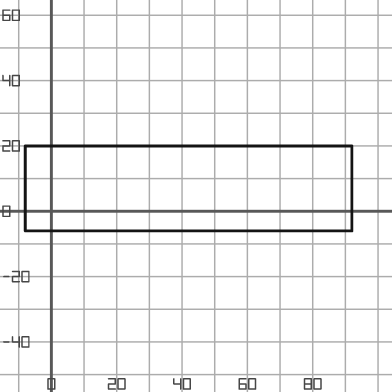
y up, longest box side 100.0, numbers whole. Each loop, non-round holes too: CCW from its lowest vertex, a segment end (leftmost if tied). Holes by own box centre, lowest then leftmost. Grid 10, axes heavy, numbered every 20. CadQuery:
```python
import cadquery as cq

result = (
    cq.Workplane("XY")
    .moveTo(-8.0, -6.0)
    .lineTo(92.0, -6.0)
    .lineTo(92.0, 20.0)
    .lineTo(-8.0, 20.0)
    .close()
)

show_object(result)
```